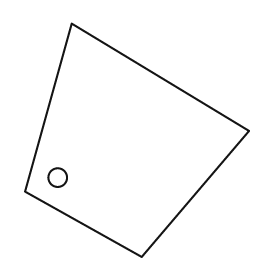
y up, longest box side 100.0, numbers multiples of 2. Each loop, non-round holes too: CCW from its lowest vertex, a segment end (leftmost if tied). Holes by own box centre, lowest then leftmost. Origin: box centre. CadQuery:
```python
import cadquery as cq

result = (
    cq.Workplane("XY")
    .moveTo(2.0, -50.0)
    .lineTo(48.0, 4.0)
    .lineTo(-28.0, 50.0)
    .lineTo(-48.0, -22.0)
    .close()
    .moveTo(-34.0, -16.0)
    .circle(4.0)
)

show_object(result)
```